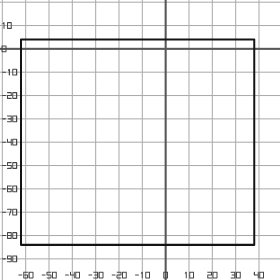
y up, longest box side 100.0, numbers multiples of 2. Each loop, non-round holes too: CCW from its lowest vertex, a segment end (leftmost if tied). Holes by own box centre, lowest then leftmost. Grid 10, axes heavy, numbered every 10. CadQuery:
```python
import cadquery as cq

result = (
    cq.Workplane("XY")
    .moveTo(-62.0, -84.0)
    .lineTo(38.0, -84.0)
    .lineTo(38.0, 4.0)
    .lineTo(-62.0, 4.0)
    .close()
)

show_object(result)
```